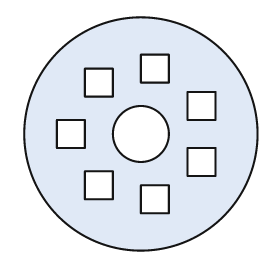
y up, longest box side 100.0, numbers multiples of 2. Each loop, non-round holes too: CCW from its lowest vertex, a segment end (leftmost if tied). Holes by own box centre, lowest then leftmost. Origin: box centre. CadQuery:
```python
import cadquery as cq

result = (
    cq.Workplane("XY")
    .moveTo(0.0, 0.0)
    .circle(50.0)
    .moveTo(0.0, -34.0)
    .lineTo(12.0, -34.0)
    .lineTo(12.0, -22.0)
    .lineTo(0.0, -22.0)
    .close()
    .moveTo(-24.0, -28.0)
    .lineTo(-12.0, -28.0)
    .lineTo(-12.0, -16.0)
    .lineTo(-24.0, -16.0)
    .close()
    .moveTo(20.0, -18.0)
    .lineTo(32.0, -18.0)
    .lineTo(32.0, -6.0)
    .lineTo(20.0, -6.0)
    .close()
    .moveTo(-36.0, -6.0)
    .lineTo(-24.0, -6.0)
    .lineTo(-24.0, 6.0)
    .lineTo(-36.0, 6.0)
    .close()
    .moveTo(0.0, 0.0)
    .circle(12.0)
    .moveTo(20.0, 6.0)
    .lineTo(32.0, 6.0)
    .lineTo(32.0, 18.0)
    .lineTo(20.0, 18.0)
    .close()
    .moveTo(-24.0, 16.0)
    .lineTo(-12.0, 16.0)
    .lineTo(-12.0, 28.0)
    .lineTo(-24.0, 28.0)
    .close()
    .moveTo(0.0, 22.0)
    .lineTo(12.0, 22.0)
    .lineTo(12.0, 34.0)
    .lineTo(0.0, 34.0)
    .close()
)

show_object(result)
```